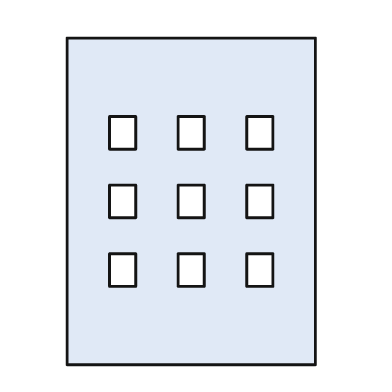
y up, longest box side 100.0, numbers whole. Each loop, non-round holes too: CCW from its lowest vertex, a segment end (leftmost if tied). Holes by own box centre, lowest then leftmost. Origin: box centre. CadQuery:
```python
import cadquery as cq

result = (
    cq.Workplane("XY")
    .moveTo(-38.0, -50.0)
    .lineTo(38.0, -50.0)
    .lineTo(38.0, 50.0)
    .lineTo(-38.0, 50.0)
    .close()
    .moveTo(-25.0, -26.0)
    .lineTo(-17.0, -26.0)
    .lineTo(-17.0, -16.0)
    .lineTo(-25.0, -16.0)
    .close()
    .moveTo(-4.0, -26.0)
    .lineTo(4.0, -26.0)
    .lineTo(4.0, -16.0)
    .lineTo(-4.0, -16.0)
    .close()
    .moveTo(17.0, -26.0)
    .lineTo(25.0, -26.0)
    .lineTo(25.0, -16.0)
    .lineTo(17.0, -16.0)
    .close()
    .moveTo(-25.0, -5.0)
    .lineTo(-17.0, -5.0)
    .lineTo(-17.0, 5.0)
    .lineTo(-25.0, 5.0)
    .close()
    .moveTo(-4.0, -5.0)
    .lineTo(4.0, -5.0)
    .lineTo(4.0, 5.0)
    .lineTo(-4.0, 5.0)
    .close()
    .moveTo(17.0, -5.0)
    .lineTo(25.0, -5.0)
    .lineTo(25.0, 5.0)
    .lineTo(17.0, 5.0)
    .close()
    .moveTo(-25.0, 16.0)
    .lineTo(-17.0, 16.0)
    .lineTo(-17.0, 26.0)
    .lineTo(-25.0, 26.0)
    .close()
    .moveTo(-4.0, 16.0)
    .lineTo(4.0, 16.0)
    .lineTo(4.0, 26.0)
    .lineTo(-4.0, 26.0)
    .close()
    .moveTo(17.0, 16.0)
    .lineTo(25.0, 16.0)
    .lineTo(25.0, 26.0)
    .lineTo(17.0, 26.0)
    .close()
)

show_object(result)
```